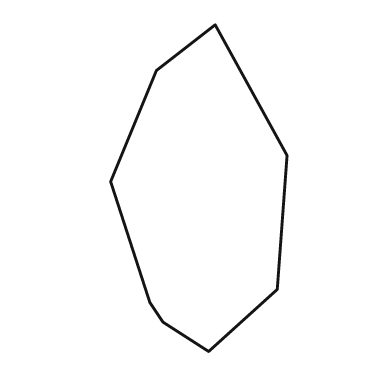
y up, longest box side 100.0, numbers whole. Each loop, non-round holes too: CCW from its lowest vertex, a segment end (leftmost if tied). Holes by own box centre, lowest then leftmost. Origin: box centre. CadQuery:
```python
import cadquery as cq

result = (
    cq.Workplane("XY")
    .moveTo(3.0, -50.0)
    .lineTo(24.0, -31.0)
    .lineTo(27.0, 10.0)
    .lineTo(5.0, 50.0)
    .lineTo(-13.0, 36.0)
    .lineTo(-27.0, 2.0)
    .lineTo(-15.0, -35.0)
    .lineTo(-11.0, -41.0)
    .close()
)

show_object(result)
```